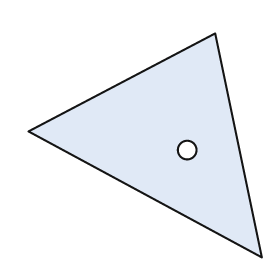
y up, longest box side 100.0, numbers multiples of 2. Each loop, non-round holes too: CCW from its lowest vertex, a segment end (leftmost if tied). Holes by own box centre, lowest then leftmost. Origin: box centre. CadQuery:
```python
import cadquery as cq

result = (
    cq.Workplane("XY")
    .moveTo(50.0, -48.0)
    .lineTo(30.0, 48.0)
    .lineTo(-50.0, 6.0)
    .close()
    .moveTo(18.0, -2.0)
    .circle(4.0)
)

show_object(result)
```